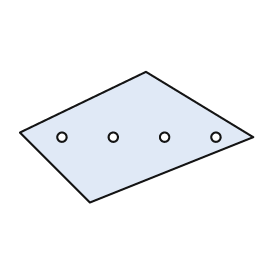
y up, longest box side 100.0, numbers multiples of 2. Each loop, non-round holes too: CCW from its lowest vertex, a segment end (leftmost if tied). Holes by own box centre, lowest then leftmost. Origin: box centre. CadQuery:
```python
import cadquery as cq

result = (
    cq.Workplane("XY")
    .moveTo(-20.0, -28.0)
    .lineTo(50.0, 0.0)
    .lineTo(4.0, 28.0)
    .lineTo(-50.0, 2.0)
    .close()
    .moveTo(-32.0, 0.0)
    .circle(2.0)
    .moveTo(-10.0, 0.0)
    .circle(2.0)
    .moveTo(12.0, 0.0)
    .circle(2.0)
    .moveTo(34.0, 0.0)
    .circle(2.0)
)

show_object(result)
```